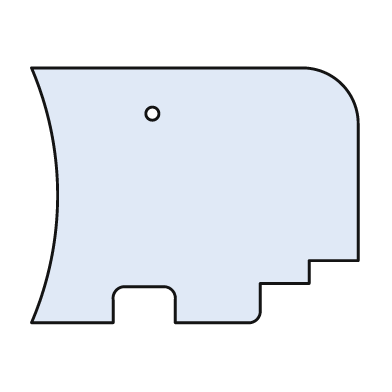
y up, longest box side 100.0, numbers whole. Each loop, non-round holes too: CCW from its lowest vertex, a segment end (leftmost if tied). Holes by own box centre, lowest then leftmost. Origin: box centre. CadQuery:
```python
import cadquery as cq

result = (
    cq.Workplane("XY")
    .moveTo(-50.0, -39.0)
    .lineTo(-25.0, -39.0)
    .lineTo(-25.0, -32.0)
    .threePointArc((-24.0, -29.0), (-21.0, -28.0))
    .lineTo(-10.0, -28.0)
    .threePointArc((-7.0, -29.0), (-6.0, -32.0))
    .lineTo(-6.0, -39.0)
    .lineTo(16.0, -39.0)
    .threePointArc((19.0, -38.0), (20.0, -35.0))
    .lineTo(20.0, -27.0)
    .lineTo(35.0, -27.0)
    .lineTo(35.0, -20.0)
    .lineTo(50.0, -20.0)
    .lineTo(50.0, 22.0)
    .threePointArc((45.0, 34.0), (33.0, 39.0))
    .lineTo(-50.0, 39.0)
    .threePointArc((-42.0, 0.0), (-50.0, -39.0))
    .close()
    .moveTo(-13.0, 25.0)
    .circle(2.0)
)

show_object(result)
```